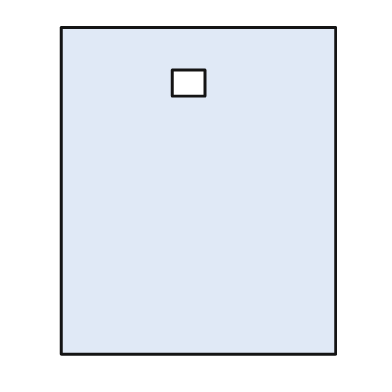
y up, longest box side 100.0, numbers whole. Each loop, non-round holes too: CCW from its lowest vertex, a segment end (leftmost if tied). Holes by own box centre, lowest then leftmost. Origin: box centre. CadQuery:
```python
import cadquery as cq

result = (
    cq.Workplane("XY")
    .moveTo(-42.0, -50.0)
    .lineTo(42.0, -50.0)
    .lineTo(42.0, 50.0)
    .lineTo(-42.0, 50.0)
    .close()
    .moveTo(-8.0, 29.0)
    .lineTo(2.0, 29.0)
    .lineTo(2.0, 37.0)
    .lineTo(-8.0, 37.0)
    .close()
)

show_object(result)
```